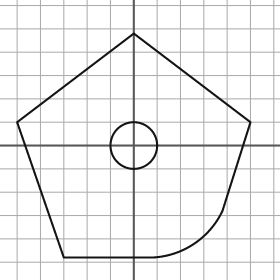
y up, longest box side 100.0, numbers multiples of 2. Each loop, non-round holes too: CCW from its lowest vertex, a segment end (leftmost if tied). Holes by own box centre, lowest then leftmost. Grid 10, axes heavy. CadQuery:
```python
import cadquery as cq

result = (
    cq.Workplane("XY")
    .moveTo(-30.0, -48.0)
    .lineTo(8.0, -48.0)
    .threePointArc((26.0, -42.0), (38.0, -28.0))
    .lineTo(50.0, 10.0)
    .lineTo(0.0, 48.0)
    .lineTo(-50.0, 10.0)
    .close()
    .moveTo(0.0, 0.0)
    .circle(10.0)
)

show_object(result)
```